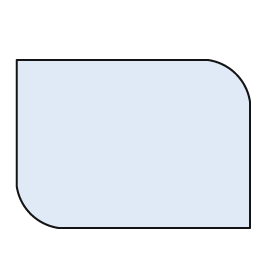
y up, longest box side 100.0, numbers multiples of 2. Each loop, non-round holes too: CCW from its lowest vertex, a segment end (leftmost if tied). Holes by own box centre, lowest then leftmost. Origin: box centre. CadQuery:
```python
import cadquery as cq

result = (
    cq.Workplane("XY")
    .moveTo(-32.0, -36.0)
    .lineTo(50.0, -36.0)
    .lineTo(50.0, 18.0)
    .threePointArc((44.0, 30.0), (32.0, 36.0))
    .lineTo(-50.0, 36.0)
    .lineTo(-50.0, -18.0)
    .threePointArc((-44.0, -30.0), (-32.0, -36.0))
    .close()
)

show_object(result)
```